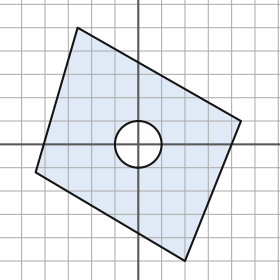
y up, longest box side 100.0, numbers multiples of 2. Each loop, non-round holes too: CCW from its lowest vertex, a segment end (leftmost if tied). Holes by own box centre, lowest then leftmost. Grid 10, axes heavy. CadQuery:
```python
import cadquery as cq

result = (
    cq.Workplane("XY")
    .moveTo(20.0, -50.0)
    .lineTo(44.0, 10.0)
    .lineTo(-26.0, 50.0)
    .lineTo(-44.0, -12.0)
    .close()
    .moveTo(0.0, 0.0)
    .circle(10.0)
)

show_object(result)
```